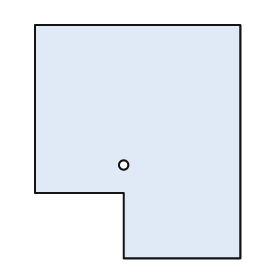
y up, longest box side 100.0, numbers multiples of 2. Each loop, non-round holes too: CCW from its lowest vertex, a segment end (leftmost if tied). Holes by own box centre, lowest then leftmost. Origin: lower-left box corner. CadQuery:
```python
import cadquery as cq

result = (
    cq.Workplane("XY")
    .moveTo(38.0, 0.0)
    .lineTo(88.0, 0.0)
    .lineTo(88.0, 100.0)
    .lineTo(0.0, 100.0)
    .lineTo(0.0, 28.0)
    .lineTo(38.0, 28.0)
    .close()
    .moveTo(38.0, 40.0)
    .circle(2.0)
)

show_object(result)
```